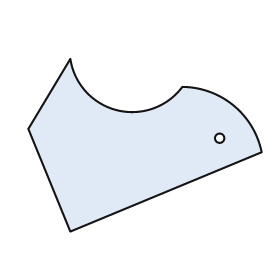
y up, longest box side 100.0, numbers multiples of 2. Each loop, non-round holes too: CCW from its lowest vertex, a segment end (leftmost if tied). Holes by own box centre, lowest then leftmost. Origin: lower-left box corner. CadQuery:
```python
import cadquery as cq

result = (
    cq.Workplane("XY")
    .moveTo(18.0, 0.0)
    .lineTo(100.0, 34.0)
    .threePointArc((88.0, 54.0), (66.0, 62.0))
    .threePointArc((38.0, 52.0), (18.0, 74.0))
    .lineTo(0.0, 44.0)
    .close()
    .moveTo(82.0, 40.0)
    .circle(2.0)
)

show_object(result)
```